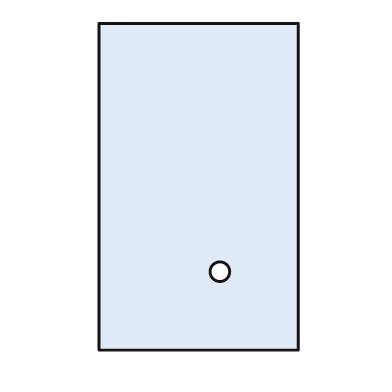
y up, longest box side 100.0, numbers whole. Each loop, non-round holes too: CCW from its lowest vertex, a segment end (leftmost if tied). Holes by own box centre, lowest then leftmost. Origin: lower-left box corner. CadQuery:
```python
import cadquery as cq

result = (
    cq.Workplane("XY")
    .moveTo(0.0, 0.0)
    .lineTo(61.0, 0.0)
    .lineTo(61.0, 100.0)
    .lineTo(0.0, 100.0)
    .close()
    .moveTo(37.0, 24.0)
    .circle(3.0)
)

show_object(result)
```